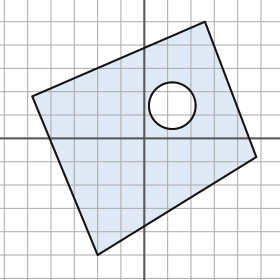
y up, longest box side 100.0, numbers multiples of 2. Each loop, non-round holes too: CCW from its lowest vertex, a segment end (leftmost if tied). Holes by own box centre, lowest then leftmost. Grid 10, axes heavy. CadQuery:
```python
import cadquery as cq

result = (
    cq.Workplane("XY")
    .moveTo(-20.0, -50.0)
    .lineTo(48.0, -8.0)
    .lineTo(26.0, 50.0)
    .lineTo(-48.0, 18.0)
    .close()
    .moveTo(12.0, 14.0)
    .circle(10.0)
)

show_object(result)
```